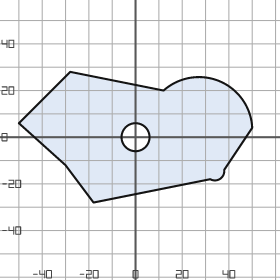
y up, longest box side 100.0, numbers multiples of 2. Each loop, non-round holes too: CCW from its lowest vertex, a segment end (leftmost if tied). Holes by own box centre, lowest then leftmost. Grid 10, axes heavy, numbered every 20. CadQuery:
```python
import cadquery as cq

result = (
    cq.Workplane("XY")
    .moveTo(-18.0, -28.0)
    .lineTo(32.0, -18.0)
    .threePointArc((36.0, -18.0), (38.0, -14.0))
    .lineTo(50.0, 4.0)
    .threePointArc((36.0, 24.0), (12.0, 20.0))
    .lineTo(-28.0, 28.0)
    .lineTo(-50.0, 6.0)
    .lineTo(-30.0, -12.0)
    .close()
    .moveTo(0.0, 0.0)
    .circle(6.0)
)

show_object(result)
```